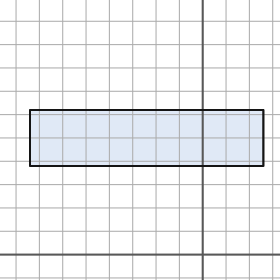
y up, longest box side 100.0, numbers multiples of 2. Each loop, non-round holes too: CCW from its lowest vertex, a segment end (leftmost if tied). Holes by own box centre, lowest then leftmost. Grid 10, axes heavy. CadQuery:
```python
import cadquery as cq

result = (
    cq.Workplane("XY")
    .moveTo(-74.0, 38.0)
    .lineTo(26.0, 38.0)
    .lineTo(26.0, 62.0)
    .lineTo(-74.0, 62.0)
    .close()
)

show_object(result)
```